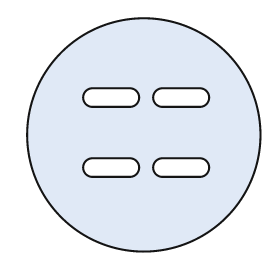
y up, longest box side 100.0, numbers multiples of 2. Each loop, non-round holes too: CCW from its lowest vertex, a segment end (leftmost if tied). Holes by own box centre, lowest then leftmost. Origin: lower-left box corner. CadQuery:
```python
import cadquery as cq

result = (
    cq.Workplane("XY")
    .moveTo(50.0, 50.0)
    .circle(50.0)
    .moveTo(28.0, 32.0)
    .lineTo(44.0, 32.0)
    .threePointArc((48.0, 36.0), (44.0, 40.0))
    .lineTo(28.0, 40.0)
    .threePointArc((24.0, 36.0), (28.0, 32.0))
    .close()
    .moveTo(58.0, 32.0)
    .lineTo(74.0, 32.0)
    .threePointArc((78.0, 36.0), (74.0, 40.0))
    .lineTo(58.0, 40.0)
    .threePointArc((54.0, 36.0), (58.0, 32.0))
    .close()
    .moveTo(28.0, 62.0)
    .lineTo(44.0, 62.0)
    .threePointArc((48.0, 66.0), (44.0, 70.0))
    .lineTo(28.0, 70.0)
    .threePointArc((24.0, 66.0), (28.0, 62.0))
    .close()
    .moveTo(58.0, 62.0)
    .lineTo(74.0, 62.0)
    .threePointArc((78.0, 66.0), (74.0, 70.0))
    .lineTo(58.0, 70.0)
    .threePointArc((54.0, 66.0), (58.0, 62.0))
    .close()
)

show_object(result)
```